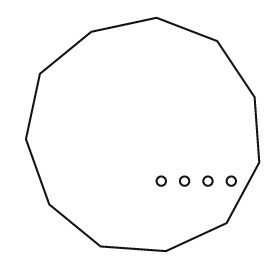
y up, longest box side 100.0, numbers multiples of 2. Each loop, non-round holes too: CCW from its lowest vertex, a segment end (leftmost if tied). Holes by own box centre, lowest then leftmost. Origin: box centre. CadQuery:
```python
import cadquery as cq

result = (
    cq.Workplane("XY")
    .moveTo(10.0, -50.0)
    .lineTo(36.0, -38.0)
    .lineTo(50.0, -12.0)
    .lineTo(48.0, 16.0)
    .lineTo(32.0, 40.0)
    .lineTo(6.0, 50.0)
    .lineTo(-22.0, 44.0)
    .lineTo(-44.0, 26.0)
    .lineTo(-50.0, -2.0)
    .lineTo(-40.0, -30.0)
    .lineTo(-18.0, -48.0)
    .close()
    .moveTo(8.0, -20.0)
    .circle(2.0)
    .moveTo(18.0, -20.0)
    .circle(2.0)
    .moveTo(28.0, -20.0)
    .circle(2.0)
    .moveTo(38.0, -20.0)
    .circle(2.0)
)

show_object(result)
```